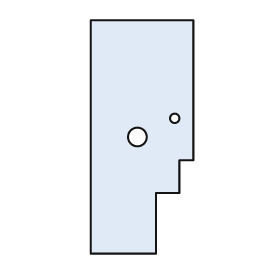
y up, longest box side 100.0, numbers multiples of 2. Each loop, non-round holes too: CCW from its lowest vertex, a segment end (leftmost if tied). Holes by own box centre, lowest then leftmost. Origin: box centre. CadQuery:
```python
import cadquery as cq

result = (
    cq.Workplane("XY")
    .moveTo(-22.0, -50.0)
    .lineTo(6.0, -50.0)
    .lineTo(6.0, -24.0)
    .lineTo(16.0, -24.0)
    .lineTo(16.0, -10.0)
    .lineTo(22.0, -10.0)
    .lineTo(22.0, 50.0)
    .lineTo(-22.0, 50.0)
    .close()
    .moveTo(-2.0, 0.0)
    .circle(4.0)
    .moveTo(14.0, 8.0)
    .circle(2.0)
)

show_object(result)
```